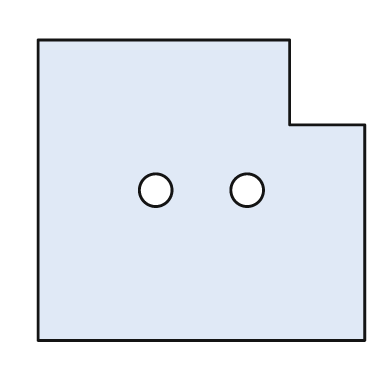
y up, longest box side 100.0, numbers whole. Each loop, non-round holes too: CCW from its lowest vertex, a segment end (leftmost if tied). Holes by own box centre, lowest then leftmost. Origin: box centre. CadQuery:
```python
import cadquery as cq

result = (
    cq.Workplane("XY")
    .moveTo(-50.0, -46.0)
    .lineTo(50.0, -46.0)
    .lineTo(50.0, 20.0)
    .lineTo(27.0, 20.0)
    .lineTo(27.0, 46.0)
    .lineTo(-50.0, 46.0)
    .close()
    .moveTo(-14.0, 0.0)
    .circle(5.0)
    .moveTo(14.0, 0.0)
    .circle(5.0)
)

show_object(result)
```